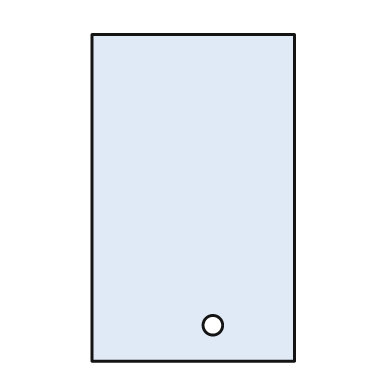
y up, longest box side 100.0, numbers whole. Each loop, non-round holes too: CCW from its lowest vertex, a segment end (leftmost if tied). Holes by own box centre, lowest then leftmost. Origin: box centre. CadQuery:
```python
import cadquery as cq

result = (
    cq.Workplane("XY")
    .moveTo(-31.0, -50.0)
    .lineTo(31.0, -50.0)
    .lineTo(31.0, 50.0)
    .lineTo(-31.0, 50.0)
    .close()
    .moveTo(6.0, -39.0)
    .circle(3.0)
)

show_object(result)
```